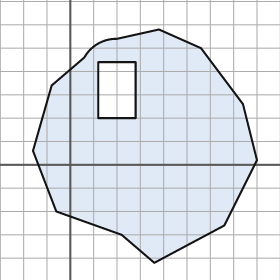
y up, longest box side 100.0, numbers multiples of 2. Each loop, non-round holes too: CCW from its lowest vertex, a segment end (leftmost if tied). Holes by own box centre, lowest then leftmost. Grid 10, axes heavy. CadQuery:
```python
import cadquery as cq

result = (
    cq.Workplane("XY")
    .moveTo(36.0, -42.0)
    .lineTo(66.0, -26.0)
    .lineTo(80.0, 2.0)
    .lineTo(74.0, 26.0)
    .lineTo(56.0, 50.0)
    .lineTo(38.0, 58.0)
    .lineTo(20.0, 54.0)
    .threePointArc((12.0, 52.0), (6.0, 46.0))
    .lineTo(-8.0, 34.0)
    .lineTo(-16.0, 6.0)
    .lineTo(-6.0, -20.0)
    .lineTo(22.0, -30.0)
    .close()
    .moveTo(12.0, 20.0)
    .lineTo(28.0, 20.0)
    .lineTo(28.0, 44.0)
    .lineTo(12.0, 44.0)
    .close()
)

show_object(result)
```